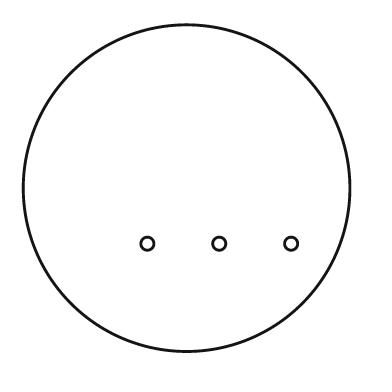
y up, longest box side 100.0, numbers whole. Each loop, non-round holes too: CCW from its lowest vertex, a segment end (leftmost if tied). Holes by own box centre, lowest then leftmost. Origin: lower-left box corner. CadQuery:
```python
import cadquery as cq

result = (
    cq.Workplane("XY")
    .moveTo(50.0, 50.0)
    .circle(50.0)
    .moveTo(38.0, 33.0)
    .circle(2.0)
    .moveTo(60.0, 33.0)
    .circle(2.0)
    .moveTo(82.0, 33.0)
    .circle(2.0)
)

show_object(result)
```